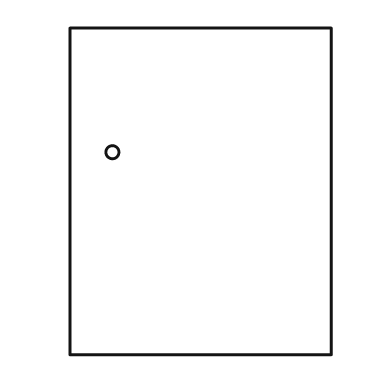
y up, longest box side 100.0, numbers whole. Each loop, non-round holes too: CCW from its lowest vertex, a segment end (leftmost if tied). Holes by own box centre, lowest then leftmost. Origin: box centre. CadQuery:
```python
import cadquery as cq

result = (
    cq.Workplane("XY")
    .moveTo(-40.0, -50.0)
    .lineTo(40.0, -50.0)
    .lineTo(40.0, 50.0)
    .lineTo(-40.0, 50.0)
    .close()
    .moveTo(-27.0, 12.0)
    .circle(2.0)
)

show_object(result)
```